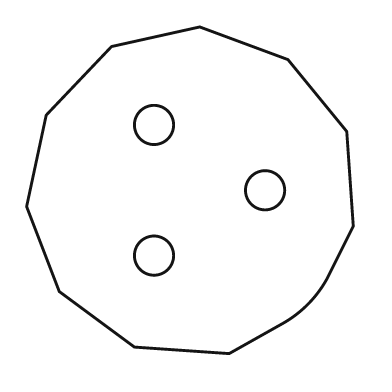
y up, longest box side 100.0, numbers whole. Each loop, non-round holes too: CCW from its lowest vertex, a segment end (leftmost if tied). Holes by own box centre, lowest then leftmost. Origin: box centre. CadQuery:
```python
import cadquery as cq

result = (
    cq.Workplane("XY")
    .moveTo(12.0, -50.0)
    .lineTo(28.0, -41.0)
    .threePointArc((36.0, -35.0), (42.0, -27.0))
    .lineTo(50.0, -11.0)
    .lineTo(48.0, 18.0)
    .lineTo(30.0, 40.0)
    .lineTo(3.0, 50.0)
    .lineTo(-24.0, 44.0)
    .lineTo(-44.0, 23.0)
    .lineTo(-50.0, -5.0)
    .lineTo(-40.0, -31.0)
    .lineTo(-17.0, -48.0)
    .close()
    .moveTo(-11.0, -20.0)
    .circle(6.0)
    .moveTo(23.0, 0.0)
    .circle(6.0)
    .moveTo(-11.0, 20.0)
    .circle(6.0)
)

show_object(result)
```